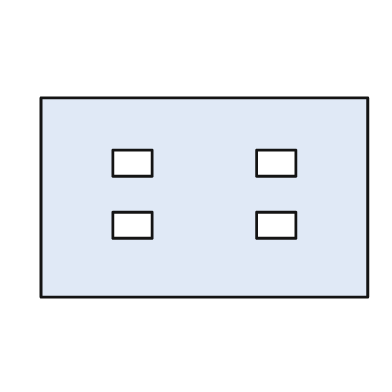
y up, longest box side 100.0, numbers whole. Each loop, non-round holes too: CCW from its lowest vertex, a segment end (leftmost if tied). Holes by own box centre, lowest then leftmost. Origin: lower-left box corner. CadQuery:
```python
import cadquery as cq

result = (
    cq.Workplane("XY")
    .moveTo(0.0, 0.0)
    .lineTo(100.0, 0.0)
    .lineTo(100.0, 61.0)
    .lineTo(0.0, 61.0)
    .close()
    .moveTo(22.0, 18.0)
    .lineTo(34.0, 18.0)
    .lineTo(34.0, 26.0)
    .lineTo(22.0, 26.0)
    .close()
    .moveTo(66.0, 18.0)
    .lineTo(78.0, 18.0)
    .lineTo(78.0, 26.0)
    .lineTo(66.0, 26.0)
    .close()
    .moveTo(22.0, 37.0)
    .lineTo(34.0, 37.0)
    .lineTo(34.0, 45.0)
    .lineTo(22.0, 45.0)
    .close()
    .moveTo(66.0, 37.0)
    .lineTo(78.0, 37.0)
    .lineTo(78.0, 45.0)
    .lineTo(66.0, 45.0)
    .close()
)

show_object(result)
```